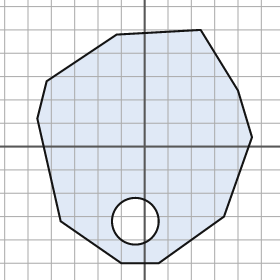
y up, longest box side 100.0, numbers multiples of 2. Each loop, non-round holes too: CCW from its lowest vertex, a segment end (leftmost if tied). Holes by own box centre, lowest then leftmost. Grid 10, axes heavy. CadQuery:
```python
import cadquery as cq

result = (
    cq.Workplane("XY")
    .moveTo(-10.0, -50.0)
    .lineTo(6.0, -50.0)
    .lineTo(34.0, -30.0)
    .lineTo(46.0, 4.0)
    .lineTo(40.0, 24.0)
    .lineTo(24.0, 50.0)
    .lineTo(-12.0, 48.0)
    .lineTo(-42.0, 28.0)
    .lineTo(-46.0, 12.0)
    .lineTo(-36.0, -32.0)
    .close()
    .moveTo(-4.0, -32.0)
    .circle(10.0)
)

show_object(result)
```